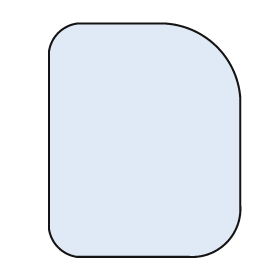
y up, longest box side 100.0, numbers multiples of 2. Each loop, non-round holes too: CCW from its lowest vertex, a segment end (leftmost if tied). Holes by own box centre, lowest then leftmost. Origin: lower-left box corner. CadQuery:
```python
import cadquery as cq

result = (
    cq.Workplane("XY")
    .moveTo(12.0, 0.0)
    .lineTo(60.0, 0.0)
    .threePointArc((76.0, 6.0), (82.0, 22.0))
    .lineTo(82.0, 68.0)
    .threePointArc((72.0, 90.0), (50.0, 100.0))
    .lineTo(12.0, 100.0)
    .threePointArc((4.0, 96.0), (0.0, 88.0))
    .lineTo(0.0, 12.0)
    .threePointArc((4.0, 4.0), (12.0, 0.0))
    .close()
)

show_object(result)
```